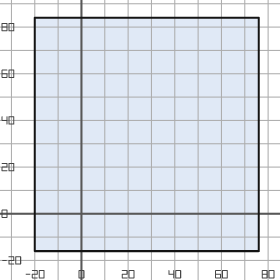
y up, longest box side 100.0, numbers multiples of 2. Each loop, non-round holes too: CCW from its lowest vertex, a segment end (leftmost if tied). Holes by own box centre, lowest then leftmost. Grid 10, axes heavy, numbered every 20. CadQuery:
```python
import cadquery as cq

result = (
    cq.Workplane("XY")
    .moveTo(-20.0, -16.0)
    .lineTo(76.0, -16.0)
    .lineTo(76.0, 84.0)
    .lineTo(-20.0, 84.0)
    .close()
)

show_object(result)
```